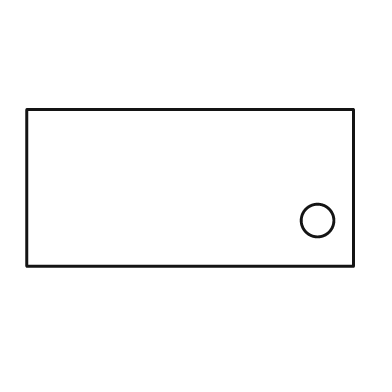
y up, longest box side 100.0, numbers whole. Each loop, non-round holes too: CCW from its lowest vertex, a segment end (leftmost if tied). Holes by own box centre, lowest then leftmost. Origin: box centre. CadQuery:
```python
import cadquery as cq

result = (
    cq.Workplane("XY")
    .moveTo(-50.0, -24.0)
    .lineTo(50.0, -24.0)
    .lineTo(50.0, 24.0)
    .lineTo(-50.0, 24.0)
    .close()
    .moveTo(39.0, -10.0)
    .circle(5.0)
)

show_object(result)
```